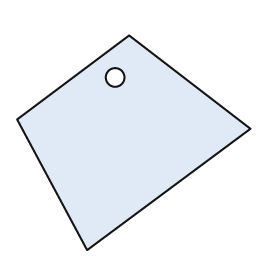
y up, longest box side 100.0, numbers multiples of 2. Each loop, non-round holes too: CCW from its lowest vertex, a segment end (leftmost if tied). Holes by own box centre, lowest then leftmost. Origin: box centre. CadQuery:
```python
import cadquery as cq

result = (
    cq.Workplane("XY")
    .moveTo(-20.0, -46.0)
    .lineTo(50.0, 6.0)
    .lineTo(-2.0, 46.0)
    .lineTo(-50.0, 10.0)
    .close()
    .moveTo(-8.0, 28.0)
    .circle(4.0)
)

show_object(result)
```